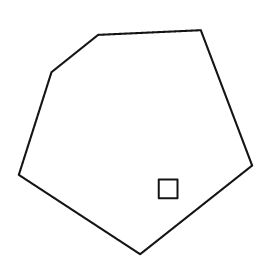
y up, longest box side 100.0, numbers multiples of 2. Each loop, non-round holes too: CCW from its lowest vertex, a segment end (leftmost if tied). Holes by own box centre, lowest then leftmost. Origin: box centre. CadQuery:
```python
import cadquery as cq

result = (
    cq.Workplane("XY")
    .moveTo(2.0, -48.0)
    .lineTo(50.0, -10.0)
    .lineTo(28.0, 48.0)
    .lineTo(-16.0, 46.0)
    .lineTo(-36.0, 30.0)
    .lineTo(-50.0, -14.0)
    .close()
    .moveTo(10.0, -24.0)
    .lineTo(18.0, -24.0)
    .lineTo(18.0, -16.0)
    .lineTo(10.0, -16.0)
    .close()
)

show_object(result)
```